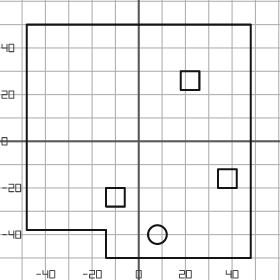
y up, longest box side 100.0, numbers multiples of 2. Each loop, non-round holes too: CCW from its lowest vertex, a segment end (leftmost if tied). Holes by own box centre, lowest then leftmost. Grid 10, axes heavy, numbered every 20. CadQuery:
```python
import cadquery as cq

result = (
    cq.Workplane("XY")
    .moveTo(-14.0, -50.0)
    .lineTo(48.0, -50.0)
    .lineTo(48.0, 50.0)
    .lineTo(-48.0, 50.0)
    .lineTo(-48.0, -38.0)
    .lineTo(-14.0, -38.0)
    .close()
    .moveTo(8.0, -40.0)
    .circle(4.0)
    .moveTo(-14.0, -28.0)
    .lineTo(-6.0, -28.0)
    .lineTo(-6.0, -20.0)
    .lineTo(-14.0, -20.0)
    .close()
    .moveTo(34.0, -20.0)
    .lineTo(42.0, -20.0)
    .lineTo(42.0, -12.0)
    .lineTo(34.0, -12.0)
    .close()
    .moveTo(18.0, 22.0)
    .lineTo(26.0, 22.0)
    .lineTo(26.0, 30.0)
    .lineTo(18.0, 30.0)
    .close()
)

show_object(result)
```